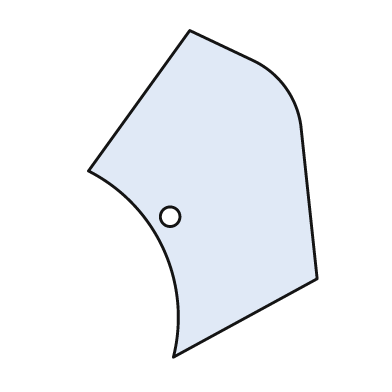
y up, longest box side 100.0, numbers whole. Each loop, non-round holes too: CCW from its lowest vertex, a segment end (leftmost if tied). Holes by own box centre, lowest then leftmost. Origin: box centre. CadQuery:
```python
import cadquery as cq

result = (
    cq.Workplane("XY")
    .moveTo(-9.0, -50.0)
    .lineTo(35.0, -26.0)
    .lineTo(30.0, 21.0)
    .threePointArc((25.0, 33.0), (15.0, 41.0))
    .lineTo(-4.0, 50.0)
    .lineTo(-35.0, 7.0)
    .threePointArc((-12.0, -17.0), (-9.0, -50.0))
    .close()
    .moveTo(-10.0, -7.0)
    .circle(3.0)
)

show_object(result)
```